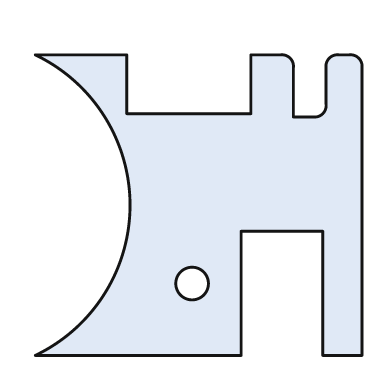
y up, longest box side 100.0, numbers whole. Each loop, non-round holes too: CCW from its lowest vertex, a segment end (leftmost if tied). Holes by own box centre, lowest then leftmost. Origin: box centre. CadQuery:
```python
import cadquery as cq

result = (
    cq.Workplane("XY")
    .moveTo(-50.0, -46.0)
    .lineTo(13.0, -46.0)
    .lineTo(13.0, -8.0)
    .lineTo(38.0, -8.0)
    .lineTo(38.0, -46.0)
    .lineTo(50.0, -46.0)
    .lineTo(50.0, 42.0)
    .threePointArc((49.0, 45.0), (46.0, 46.0))
    .lineTo(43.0, 46.0)
    .threePointArc((40.0, 45.0), (39.0, 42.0))
    .lineTo(39.0, 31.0)
    .threePointArc((38.0, 28.0), (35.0, 27.0))
    .lineTo(29.0, 27.0)
    .lineTo(29.0, 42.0)
    .threePointArc((28.0, 45.0), (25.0, 46.0))
    .lineTo(16.0, 46.0)
    .lineTo(16.0, 28.0)
    .lineTo(-22.0, 28.0)
    .lineTo(-22.0, 46.0)
    .lineTo(-50.0, 46.0)
    .threePointArc((-21.0, 0.0), (-50.0, -46.0))
    .close()
    .moveTo(-2.0, -24.0)
    .circle(5.0)
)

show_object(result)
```